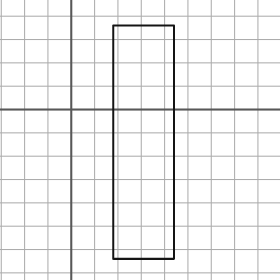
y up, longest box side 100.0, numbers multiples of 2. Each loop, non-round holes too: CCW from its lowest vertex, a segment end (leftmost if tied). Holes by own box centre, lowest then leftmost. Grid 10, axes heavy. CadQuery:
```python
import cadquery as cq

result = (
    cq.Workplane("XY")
    .moveTo(18.0, -64.0)
    .lineTo(44.0, -64.0)
    .lineTo(44.0, 36.0)
    .lineTo(18.0, 36.0)
    .close()
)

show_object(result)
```